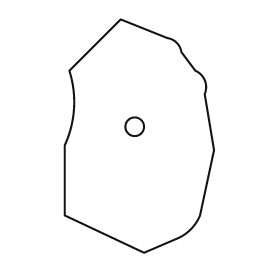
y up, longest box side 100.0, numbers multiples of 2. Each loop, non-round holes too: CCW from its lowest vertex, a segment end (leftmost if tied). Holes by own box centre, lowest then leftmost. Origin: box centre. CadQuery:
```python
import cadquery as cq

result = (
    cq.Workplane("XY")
    .moveTo(2.0, -50.0)
    .lineTo(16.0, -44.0)
    .threePointArc((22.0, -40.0), (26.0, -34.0))
    .lineTo(32.0, -6.0)
    .lineTo(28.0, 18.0)
    .threePointArc((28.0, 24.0), (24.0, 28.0))
    .lineTo(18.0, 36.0)
    .threePointArc((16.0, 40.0), (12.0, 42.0))
    .lineTo(-8.0, 50.0)
    .lineTo(-30.0, 28.0)
    .threePointArc((-28.0, 12.0), (-32.0, -4.0))
    .lineTo(-32.0, -34.0)
    .close()
    .moveTo(-2.0, 4.0)
    .circle(4.0)
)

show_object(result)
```